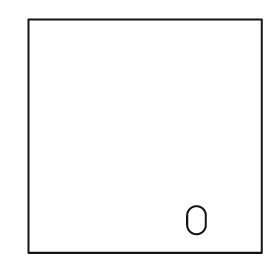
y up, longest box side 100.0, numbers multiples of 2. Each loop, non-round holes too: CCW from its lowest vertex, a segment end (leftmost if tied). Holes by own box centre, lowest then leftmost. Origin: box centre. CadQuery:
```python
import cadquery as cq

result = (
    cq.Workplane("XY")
    .moveTo(-50.0, -50.0)
    .lineTo(50.0, -50.0)
    .lineTo(50.0, 50.0)
    .lineTo(-50.0, 50.0)
    .close()
    .moveTo(18.0, -38.0)
    .threePointArc((22.0, -42.0), (26.0, -38.0))
    .lineTo(26.0, -34.0)
    .threePointArc((22.0, -30.0), (18.0, -34.0))
    .close()
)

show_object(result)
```